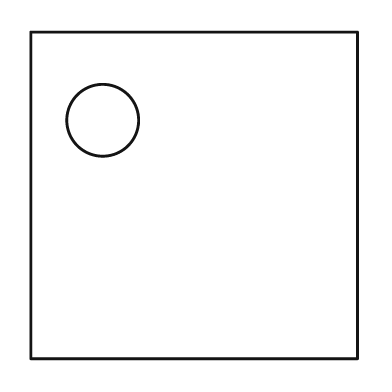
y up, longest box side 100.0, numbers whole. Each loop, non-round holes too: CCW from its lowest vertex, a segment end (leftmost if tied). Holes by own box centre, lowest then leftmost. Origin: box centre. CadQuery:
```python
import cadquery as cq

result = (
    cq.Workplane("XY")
    .moveTo(-50.0, -50.0)
    .lineTo(50.0, -50.0)
    .lineTo(50.0, 50.0)
    .lineTo(-50.0, 50.0)
    .close()
    .moveTo(-28.0, 23.0)
    .circle(11.0)
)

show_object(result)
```